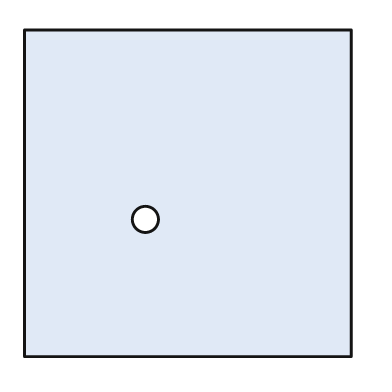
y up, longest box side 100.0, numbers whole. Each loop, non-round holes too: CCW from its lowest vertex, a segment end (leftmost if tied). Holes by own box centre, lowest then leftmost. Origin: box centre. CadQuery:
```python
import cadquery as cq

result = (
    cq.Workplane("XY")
    .moveTo(-50.0, -50.0)
    .lineTo(50.0, -50.0)
    .lineTo(50.0, 50.0)
    .lineTo(-50.0, 50.0)
    .close()
    .moveTo(-13.0, -8.0)
    .circle(4.0)
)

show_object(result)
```